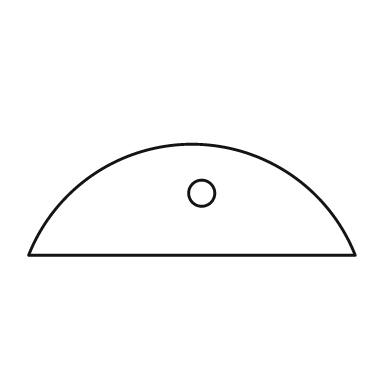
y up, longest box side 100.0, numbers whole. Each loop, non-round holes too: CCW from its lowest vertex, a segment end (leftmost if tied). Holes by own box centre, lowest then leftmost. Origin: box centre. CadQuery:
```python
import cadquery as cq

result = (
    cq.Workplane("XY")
    .moveTo(-50.0, -17.0)
    .lineTo(50.0, -17.0)
    .threePointArc((0.0, 17.0), (-50.0, -17.0))
    .close()
    .moveTo(3.0, 2.0)
    .circle(4.0)
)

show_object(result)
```